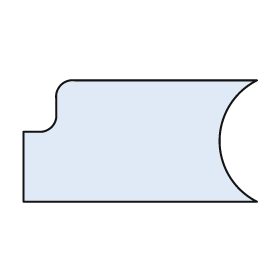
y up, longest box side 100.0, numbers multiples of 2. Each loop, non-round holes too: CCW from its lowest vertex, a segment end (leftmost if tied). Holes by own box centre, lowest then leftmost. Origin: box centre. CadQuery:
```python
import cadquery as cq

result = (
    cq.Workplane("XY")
    .moveTo(-50.0, -26.0)
    .lineTo(50.0, -26.0)
    .threePointArc((34.0, 0.0), (50.0, 26.0))
    .lineTo(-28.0, 26.0)
    .threePointArc((-34.0, 24.0), (-36.0, 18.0))
    .lineTo(-36.0, 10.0)
    .threePointArc((-38.0, 6.0), (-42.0, 4.0))
    .lineTo(-50.0, 4.0)
    .close()
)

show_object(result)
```